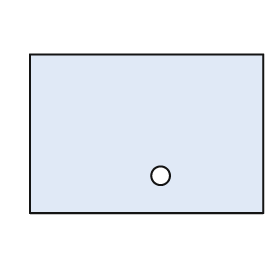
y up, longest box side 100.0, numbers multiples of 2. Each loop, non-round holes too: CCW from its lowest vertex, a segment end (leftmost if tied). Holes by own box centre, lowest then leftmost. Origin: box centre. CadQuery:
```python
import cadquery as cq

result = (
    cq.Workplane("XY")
    .moveTo(-50.0, -34.0)
    .lineTo(50.0, -34.0)
    .lineTo(50.0, 34.0)
    .lineTo(-50.0, 34.0)
    .close()
    .moveTo(6.0, -18.0)
    .circle(4.0)
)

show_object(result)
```